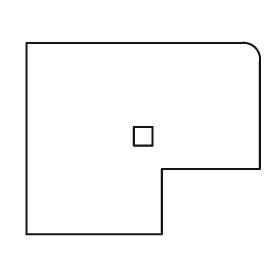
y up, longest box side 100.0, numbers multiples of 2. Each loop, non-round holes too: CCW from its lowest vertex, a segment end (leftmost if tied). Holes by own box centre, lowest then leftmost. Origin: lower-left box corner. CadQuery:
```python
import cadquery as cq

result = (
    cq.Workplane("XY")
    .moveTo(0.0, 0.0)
    .lineTo(58.0, 0.0)
    .lineTo(58.0, 28.0)
    .lineTo(100.0, 28.0)
    .lineTo(100.0, 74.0)
    .threePointArc((98.0, 80.0), (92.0, 82.0))
    .lineTo(0.0, 82.0)
    .close()
    .moveTo(46.0, 38.0)
    .lineTo(54.0, 38.0)
    .lineTo(54.0, 46.0)
    .lineTo(46.0, 46.0)
    .close()
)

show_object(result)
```